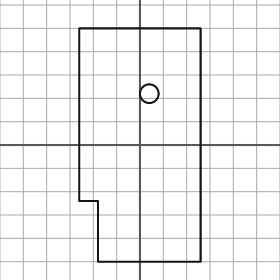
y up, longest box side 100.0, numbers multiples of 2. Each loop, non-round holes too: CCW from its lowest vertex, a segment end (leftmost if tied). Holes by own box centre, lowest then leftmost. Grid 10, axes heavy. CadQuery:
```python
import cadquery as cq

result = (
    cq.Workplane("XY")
    .moveTo(-18.0, -50.0)
    .lineTo(26.0, -50.0)
    .lineTo(26.0, 50.0)
    .lineTo(-26.0, 50.0)
    .lineTo(-26.0, -24.0)
    .lineTo(-18.0, -24.0)
    .close()
    .moveTo(4.0, 22.0)
    .circle(4.0)
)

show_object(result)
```